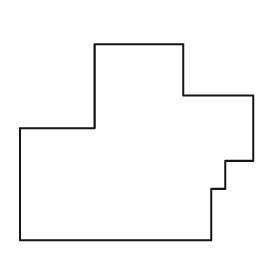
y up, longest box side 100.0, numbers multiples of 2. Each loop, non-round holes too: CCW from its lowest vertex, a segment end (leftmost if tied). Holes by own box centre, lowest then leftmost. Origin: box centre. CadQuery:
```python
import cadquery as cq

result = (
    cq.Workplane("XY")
    .moveTo(-50.0, -42.0)
    .lineTo(32.0, -42.0)
    .lineTo(32.0, -20.0)
    .lineTo(38.0, -20.0)
    .lineTo(38.0, -8.0)
    .lineTo(50.0, -8.0)
    .lineTo(50.0, 20.0)
    .lineTo(20.0, 20.0)
    .lineTo(20.0, 42.0)
    .lineTo(-18.0, 42.0)
    .lineTo(-18.0, 6.0)
    .lineTo(-50.0, 6.0)
    .close()
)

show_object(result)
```